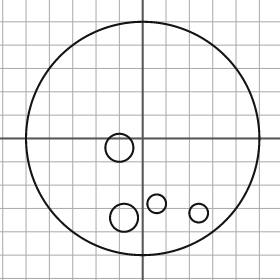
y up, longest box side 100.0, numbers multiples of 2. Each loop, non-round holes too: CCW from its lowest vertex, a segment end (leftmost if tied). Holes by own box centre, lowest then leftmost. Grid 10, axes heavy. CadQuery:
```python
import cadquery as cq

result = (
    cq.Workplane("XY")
    .moveTo(0.0, 0.0)
    .circle(50.0)
    .moveTo(-8.0, -34.0)
    .circle(6.0)
    .moveTo(24.0, -32.0)
    .circle(4.0)
    .moveTo(6.0, -28.0)
    .circle(4.0)
    .moveTo(-10.0, -4.0)
    .circle(6.0)
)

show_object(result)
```